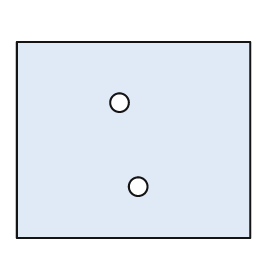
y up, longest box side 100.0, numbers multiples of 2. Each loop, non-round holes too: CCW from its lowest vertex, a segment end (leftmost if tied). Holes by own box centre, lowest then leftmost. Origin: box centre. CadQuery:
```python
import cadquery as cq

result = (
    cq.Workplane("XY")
    .moveTo(-50.0, -42.0)
    .lineTo(50.0, -42.0)
    .lineTo(50.0, 42.0)
    .lineTo(-50.0, 42.0)
    .close()
    .moveTo(2.0, -20.0)
    .circle(4.0)
    .moveTo(-6.0, 16.0)
    .circle(4.0)
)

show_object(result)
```